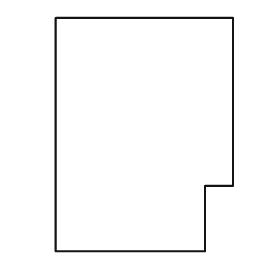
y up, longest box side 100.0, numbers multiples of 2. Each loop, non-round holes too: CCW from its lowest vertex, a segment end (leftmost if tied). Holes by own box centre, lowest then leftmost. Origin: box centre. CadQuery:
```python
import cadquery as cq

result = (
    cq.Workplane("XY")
    .moveTo(-38.0, -50.0)
    .lineTo(26.0, -50.0)
    .lineTo(26.0, -22.0)
    .lineTo(38.0, -22.0)
    .lineTo(38.0, 50.0)
    .lineTo(-38.0, 50.0)
    .close()
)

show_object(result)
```